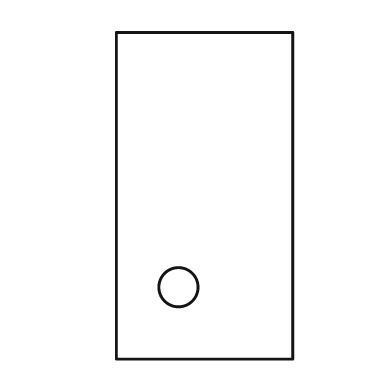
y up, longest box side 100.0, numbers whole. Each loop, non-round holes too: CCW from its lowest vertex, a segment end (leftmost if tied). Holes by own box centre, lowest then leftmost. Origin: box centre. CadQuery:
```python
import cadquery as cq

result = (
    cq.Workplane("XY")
    .moveTo(-27.0, -50.0)
    .lineTo(27.0, -50.0)
    .lineTo(27.0, 50.0)
    .lineTo(-27.0, 50.0)
    .close()
    .moveTo(-8.0, -28.0)
    .circle(6.0)
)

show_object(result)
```